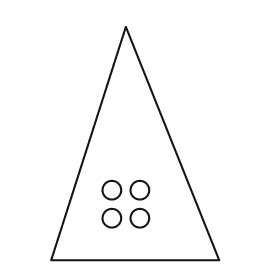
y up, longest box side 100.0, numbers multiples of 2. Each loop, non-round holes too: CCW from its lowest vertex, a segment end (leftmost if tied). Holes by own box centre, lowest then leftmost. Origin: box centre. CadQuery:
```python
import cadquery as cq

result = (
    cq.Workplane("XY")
    .moveTo(-36.0, -50.0)
    .lineTo(36.0, -50.0)
    .lineTo(-4.0, 50.0)
    .close()
    .moveTo(-10.0, -32.0)
    .circle(4.0)
    .moveTo(2.0, -32.0)
    .circle(4.0)
    .moveTo(-10.0, -20.0)
    .circle(4.0)
    .moveTo(2.0, -20.0)
    .circle(4.0)
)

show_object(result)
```